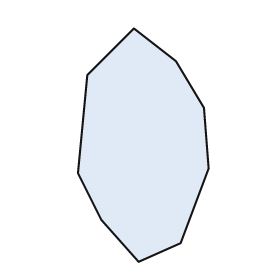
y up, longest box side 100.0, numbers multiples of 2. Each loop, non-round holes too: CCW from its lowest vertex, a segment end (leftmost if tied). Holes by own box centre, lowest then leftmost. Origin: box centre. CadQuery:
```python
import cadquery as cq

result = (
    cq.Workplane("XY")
    .moveTo(-2.0, -50.0)
    .lineTo(16.0, -42.0)
    .lineTo(28.0, -10.0)
    .lineTo(26.0, 16.0)
    .lineTo(14.0, 36.0)
    .lineTo(-4.0, 50.0)
    .lineTo(-24.0, 30.0)
    .lineTo(-28.0, -12.0)
    .lineTo(-18.0, -32.0)
    .close()
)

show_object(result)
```